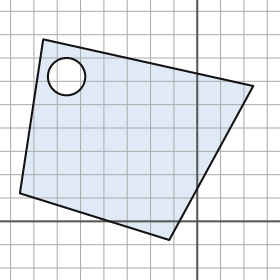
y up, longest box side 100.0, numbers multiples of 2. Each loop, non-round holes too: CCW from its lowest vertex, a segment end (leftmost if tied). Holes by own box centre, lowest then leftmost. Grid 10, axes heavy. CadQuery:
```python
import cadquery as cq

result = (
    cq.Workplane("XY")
    .moveTo(-12.0, -8.0)
    .lineTo(24.0, 58.0)
    .lineTo(-66.0, 78.0)
    .lineTo(-76.0, 12.0)
    .close()
    .moveTo(-56.0, 62.0)
    .circle(8.0)
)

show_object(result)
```